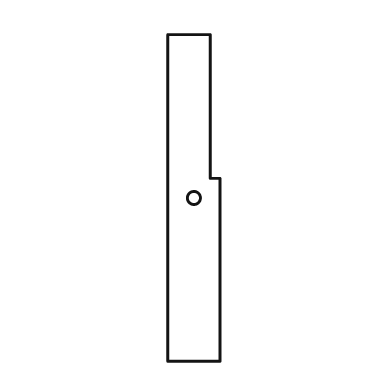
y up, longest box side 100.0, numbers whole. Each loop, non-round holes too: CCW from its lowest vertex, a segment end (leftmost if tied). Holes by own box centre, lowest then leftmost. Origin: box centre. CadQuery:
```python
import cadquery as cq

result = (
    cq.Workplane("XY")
    .moveTo(-8.0, -50.0)
    .lineTo(8.0, -50.0)
    .lineTo(8.0, 6.0)
    .lineTo(5.0, 6.0)
    .lineTo(5.0, 50.0)
    .lineTo(-8.0, 50.0)
    .close()
    .moveTo(0.0, 0.0)
    .circle(2.0)
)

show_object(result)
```